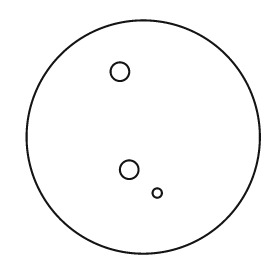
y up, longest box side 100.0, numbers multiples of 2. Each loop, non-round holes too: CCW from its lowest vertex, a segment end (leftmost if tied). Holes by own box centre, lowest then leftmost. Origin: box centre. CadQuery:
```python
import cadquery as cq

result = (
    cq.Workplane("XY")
    .moveTo(0.0, 0.0)
    .circle(50.0)
    .moveTo(6.0, -24.0)
    .circle(2.0)
    .moveTo(-6.0, -14.0)
    .circle(4.0)
    .moveTo(-10.0, 28.0)
    .circle(4.0)
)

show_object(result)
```